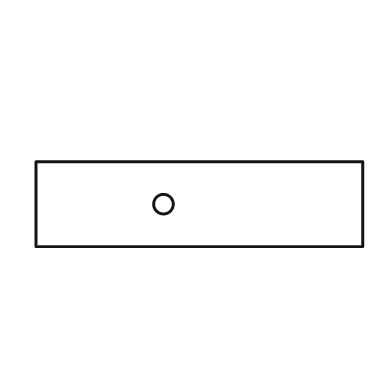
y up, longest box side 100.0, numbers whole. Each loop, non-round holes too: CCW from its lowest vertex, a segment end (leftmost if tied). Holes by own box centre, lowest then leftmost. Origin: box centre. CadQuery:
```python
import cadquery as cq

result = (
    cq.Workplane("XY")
    .moveTo(-50.0, -13.0)
    .lineTo(50.0, -13.0)
    .lineTo(50.0, 13.0)
    .lineTo(-50.0, 13.0)
    .close()
    .moveTo(-11.0, 0.0)
    .circle(3.0)
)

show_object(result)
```